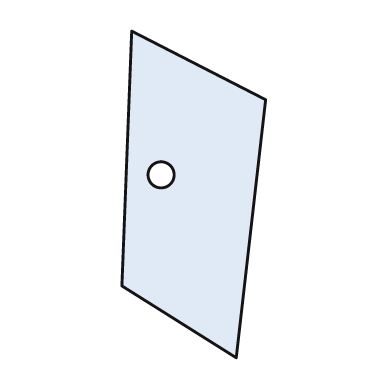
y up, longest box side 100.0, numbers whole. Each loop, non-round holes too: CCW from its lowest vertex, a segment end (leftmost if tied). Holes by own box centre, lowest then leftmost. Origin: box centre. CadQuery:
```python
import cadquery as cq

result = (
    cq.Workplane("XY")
    .moveTo(13.0, -50.0)
    .lineTo(22.0, 29.0)
    .lineTo(-19.0, 50.0)
    .lineTo(-22.0, -28.0)
    .close()
    .moveTo(-10.0, 6.0)
    .circle(4.0)
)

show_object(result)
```